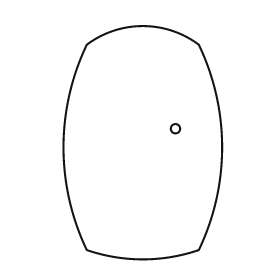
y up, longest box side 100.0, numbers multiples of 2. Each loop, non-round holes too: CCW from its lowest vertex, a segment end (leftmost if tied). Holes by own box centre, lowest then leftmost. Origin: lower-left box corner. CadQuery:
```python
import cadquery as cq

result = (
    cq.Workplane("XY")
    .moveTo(10.0, 4.0)
    .threePointArc((34.0, 0.0), (58.0, 4.0))
    .threePointArc((68.0, 48.0), (58.0, 92.0))
    .threePointArc((34.0, 100.0), (10.0, 92.0))
    .threePointArc((0.0, 48.0), (10.0, 4.0))
    .close()
    .moveTo(48.0, 56.0)
    .circle(2.0)
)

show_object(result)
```